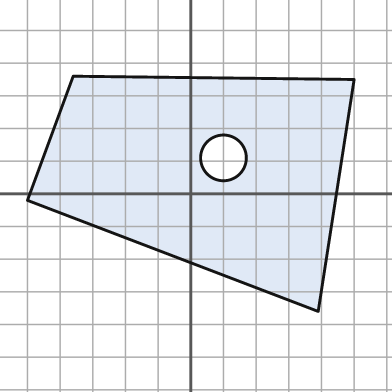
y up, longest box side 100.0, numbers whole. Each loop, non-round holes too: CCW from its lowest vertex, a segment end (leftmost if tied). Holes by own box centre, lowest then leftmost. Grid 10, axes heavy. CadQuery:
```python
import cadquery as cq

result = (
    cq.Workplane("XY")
    .moveTo(39.0, -36.0)
    .lineTo(50.0, 35.0)
    .lineTo(-36.0, 36.0)
    .lineTo(-50.0, -2.0)
    .close()
    .moveTo(10.0, 11.0)
    .circle(7.0)
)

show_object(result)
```